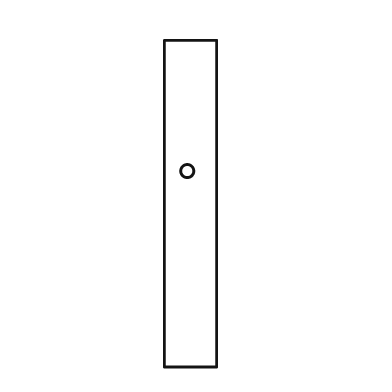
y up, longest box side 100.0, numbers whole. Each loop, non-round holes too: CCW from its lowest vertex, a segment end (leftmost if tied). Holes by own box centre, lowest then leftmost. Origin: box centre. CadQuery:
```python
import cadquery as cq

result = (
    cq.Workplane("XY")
    .moveTo(-8.0, -50.0)
    .lineTo(8.0, -50.0)
    .lineTo(8.0, 50.0)
    .lineTo(-8.0, 50.0)
    .close()
    .moveTo(-1.0, 10.0)
    .circle(2.0)
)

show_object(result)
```